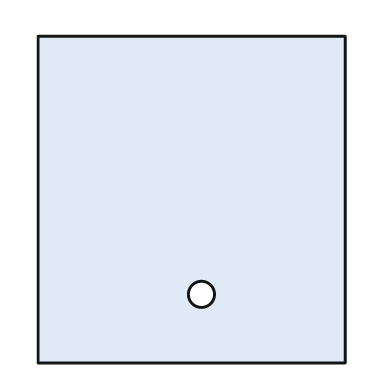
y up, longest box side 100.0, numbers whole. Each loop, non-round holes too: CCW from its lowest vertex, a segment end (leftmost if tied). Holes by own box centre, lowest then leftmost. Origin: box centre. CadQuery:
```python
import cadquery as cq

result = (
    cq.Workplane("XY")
    .moveTo(-47.0, -50.0)
    .lineTo(47.0, -50.0)
    .lineTo(47.0, 50.0)
    .lineTo(-47.0, 50.0)
    .close()
    .moveTo(3.0, -29.0)
    .circle(4.0)
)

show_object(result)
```